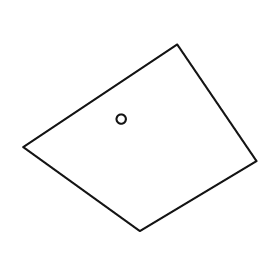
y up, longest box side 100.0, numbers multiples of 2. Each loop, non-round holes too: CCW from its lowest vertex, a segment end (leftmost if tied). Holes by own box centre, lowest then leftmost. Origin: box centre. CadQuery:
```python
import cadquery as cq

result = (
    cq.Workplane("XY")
    .moveTo(0.0, -40.0)
    .lineTo(50.0, -10.0)
    .lineTo(16.0, 40.0)
    .lineTo(-50.0, -4.0)
    .close()
    .moveTo(-8.0, 8.0)
    .circle(2.0)
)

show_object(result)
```